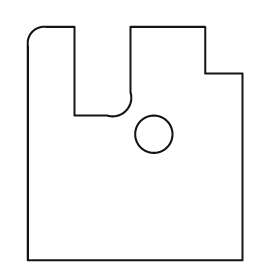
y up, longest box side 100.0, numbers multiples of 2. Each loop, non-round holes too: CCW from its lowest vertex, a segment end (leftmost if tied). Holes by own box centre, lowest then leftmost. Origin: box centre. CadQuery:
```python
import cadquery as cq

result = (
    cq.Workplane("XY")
    .moveTo(-46.0, -50.0)
    .lineTo(46.0, -50.0)
    .lineTo(46.0, 30.0)
    .lineTo(30.0, 30.0)
    .lineTo(30.0, 50.0)
    .lineTo(-2.0, 50.0)
    .lineTo(-2.0, 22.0)
    .threePointArc((-4.0, 14.0), (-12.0, 12.0))
    .lineTo(-26.0, 12.0)
    .lineTo(-26.0, 50.0)
    .lineTo(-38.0, 50.0)
    .threePointArc((-44.0, 48.0), (-46.0, 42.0))
    .close()
    .moveTo(8.0, 4.0)
    .circle(8.0)
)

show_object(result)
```